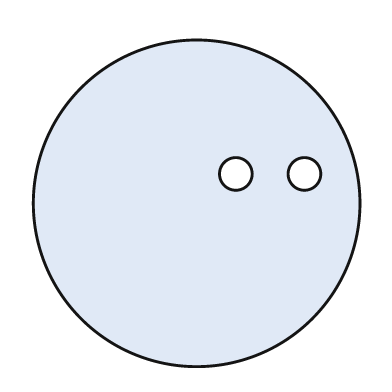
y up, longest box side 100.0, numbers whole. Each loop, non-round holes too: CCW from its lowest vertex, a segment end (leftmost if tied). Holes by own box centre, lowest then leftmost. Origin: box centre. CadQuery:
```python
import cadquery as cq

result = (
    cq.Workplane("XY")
    .moveTo(0.0, 0.0)
    .circle(50.0)
    .moveTo(12.0, 9.0)
    .circle(5.0)
    .moveTo(33.0, 9.0)
    .circle(5.0)
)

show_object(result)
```